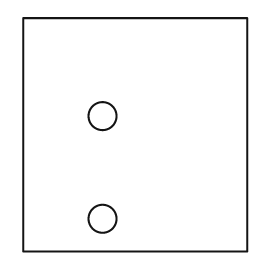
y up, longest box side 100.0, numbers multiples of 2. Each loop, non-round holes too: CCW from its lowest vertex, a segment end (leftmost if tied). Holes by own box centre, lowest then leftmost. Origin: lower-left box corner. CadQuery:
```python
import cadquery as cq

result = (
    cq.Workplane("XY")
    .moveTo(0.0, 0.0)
    .lineTo(96.0, 0.0)
    .lineTo(96.0, 100.0)
    .lineTo(0.0, 100.0)
    .close()
    .moveTo(34.0, 14.0)
    .circle(6.0)
    .moveTo(34.0, 58.0)
    .circle(6.0)
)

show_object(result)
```